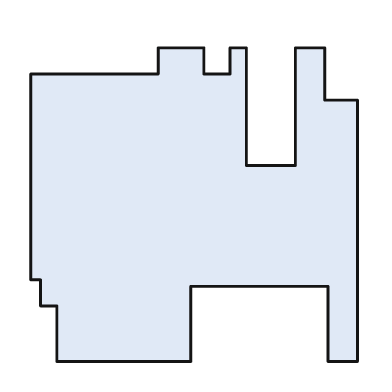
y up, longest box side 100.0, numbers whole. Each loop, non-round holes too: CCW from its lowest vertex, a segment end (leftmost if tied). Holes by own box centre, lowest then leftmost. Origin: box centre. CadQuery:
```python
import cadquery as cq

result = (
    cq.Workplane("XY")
    .moveTo(-42.0, -48.0)
    .lineTo(-1.0, -48.0)
    .lineTo(-1.0, -25.0)
    .lineTo(41.0, -25.0)
    .lineTo(41.0, -48.0)
    .lineTo(50.0, -48.0)
    .lineTo(50.0, 32.0)
    .lineTo(40.0, 32.0)
    .lineTo(40.0, 48.0)
    .lineTo(31.0, 48.0)
    .lineTo(31.0, 12.0)
    .lineTo(16.0, 12.0)
    .lineTo(16.0, 48.0)
    .lineTo(11.0, 48.0)
    .lineTo(11.0, 40.0)
    .lineTo(3.0, 40.0)
    .lineTo(3.0, 48.0)
    .lineTo(-11.0, 48.0)
    .lineTo(-11.0, 40.0)
    .lineTo(-50.0, 40.0)
    .lineTo(-50.0, -23.0)
    .lineTo(-47.0, -23.0)
    .lineTo(-47.0, -31.0)
    .lineTo(-42.0, -31.0)
    .close()
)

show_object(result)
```